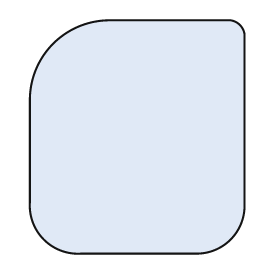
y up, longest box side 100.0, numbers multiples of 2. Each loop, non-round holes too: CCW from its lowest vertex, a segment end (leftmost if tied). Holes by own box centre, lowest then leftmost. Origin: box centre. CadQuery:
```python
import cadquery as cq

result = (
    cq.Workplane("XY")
    .moveTo(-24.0, -50.0)
    .lineTo(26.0, -50.0)
    .threePointArc((40.0, -44.0), (46.0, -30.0))
    .lineTo(46.0, 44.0)
    .threePointArc((44.0, 48.0), (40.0, 50.0))
    .lineTo(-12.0, 50.0)
    .threePointArc((-36.0, 40.0), (-46.0, 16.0))
    .lineTo(-46.0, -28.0)
    .threePointArc((-40.0, -44.0), (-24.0, -50.0))
    .close()
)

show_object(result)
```